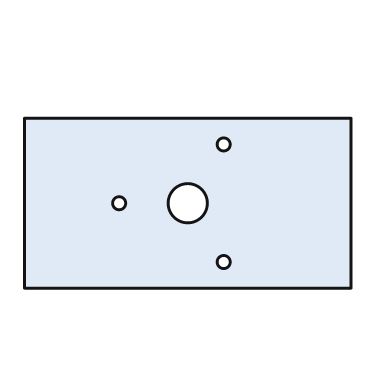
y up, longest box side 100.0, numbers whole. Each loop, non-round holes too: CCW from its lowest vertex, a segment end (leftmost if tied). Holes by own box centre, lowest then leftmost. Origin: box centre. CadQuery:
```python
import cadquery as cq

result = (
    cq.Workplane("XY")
    .moveTo(-50.0, -26.0)
    .lineTo(50.0, -26.0)
    .lineTo(50.0, 26.0)
    .lineTo(-50.0, 26.0)
    .close()
    .moveTo(11.0, -18.0)
    .circle(2.0)
    .moveTo(-21.0, 0.0)
    .circle(2.0)
    .moveTo(0.0, 0.0)
    .circle(6.0)
    .moveTo(11.0, 18.0)
    .circle(2.0)
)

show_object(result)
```